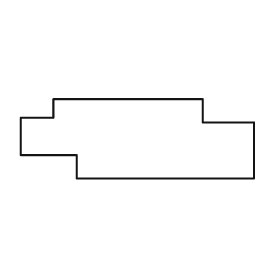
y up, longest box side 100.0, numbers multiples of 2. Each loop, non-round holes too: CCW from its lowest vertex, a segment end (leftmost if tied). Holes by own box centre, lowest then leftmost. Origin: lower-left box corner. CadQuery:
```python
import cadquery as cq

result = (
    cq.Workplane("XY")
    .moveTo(24.0, 0.0)
    .lineTo(100.0, 0.0)
    .lineTo(100.0, 24.0)
    .lineTo(78.0, 24.0)
    .lineTo(78.0, 34.0)
    .lineTo(14.0, 34.0)
    .lineTo(14.0, 26.0)
    .lineTo(0.0, 26.0)
    .lineTo(0.0, 10.0)
    .lineTo(24.0, 10.0)
    .close()
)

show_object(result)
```